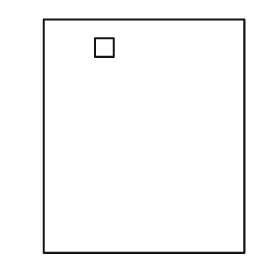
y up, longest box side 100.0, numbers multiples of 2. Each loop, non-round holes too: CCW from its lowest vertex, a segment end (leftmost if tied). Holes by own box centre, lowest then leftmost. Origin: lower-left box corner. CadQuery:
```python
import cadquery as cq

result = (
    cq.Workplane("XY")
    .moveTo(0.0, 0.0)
    .lineTo(86.0, 0.0)
    .lineTo(86.0, 100.0)
    .lineTo(0.0, 100.0)
    .close()
    .moveTo(22.0, 84.0)
    .lineTo(30.0, 84.0)
    .lineTo(30.0, 92.0)
    .lineTo(22.0, 92.0)
    .close()
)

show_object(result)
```